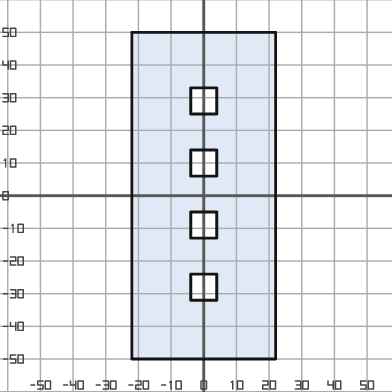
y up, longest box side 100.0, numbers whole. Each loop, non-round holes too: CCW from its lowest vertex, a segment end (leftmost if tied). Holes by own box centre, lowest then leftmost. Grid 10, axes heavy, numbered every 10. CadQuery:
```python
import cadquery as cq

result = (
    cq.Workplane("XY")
    .moveTo(-22.0, -50.0)
    .lineTo(22.0, -50.0)
    .lineTo(22.0, 50.0)
    .lineTo(-22.0, 50.0)
    .close()
    .moveTo(-4.0, -32.0)
    .lineTo(4.0, -32.0)
    .lineTo(4.0, -24.0)
    .lineTo(-4.0, -24.0)
    .close()
    .moveTo(-4.0, -13.0)
    .lineTo(4.0, -13.0)
    .lineTo(4.0, -5.0)
    .lineTo(-4.0, -5.0)
    .close()
    .moveTo(-4.0, 6.0)
    .lineTo(4.0, 6.0)
    .lineTo(4.0, 14.0)
    .lineTo(-4.0, 14.0)
    .close()
    .moveTo(-4.0, 25.0)
    .lineTo(4.0, 25.0)
    .lineTo(4.0, 33.0)
    .lineTo(-4.0, 33.0)
    .close()
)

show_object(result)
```